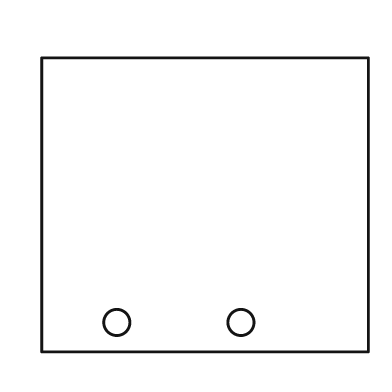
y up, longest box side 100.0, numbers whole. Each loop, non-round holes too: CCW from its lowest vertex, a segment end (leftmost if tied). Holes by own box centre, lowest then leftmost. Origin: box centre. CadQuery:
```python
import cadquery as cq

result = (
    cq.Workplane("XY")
    .moveTo(-50.0, -45.0)
    .lineTo(50.0, -45.0)
    .lineTo(50.0, 45.0)
    .lineTo(-50.0, 45.0)
    .close()
    .moveTo(-27.0, -36.0)
    .circle(4.0)
    .moveTo(11.0, -36.0)
    .circle(4.0)
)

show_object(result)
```